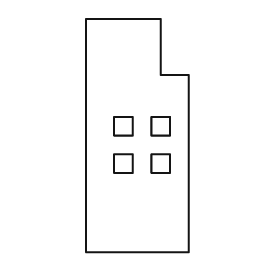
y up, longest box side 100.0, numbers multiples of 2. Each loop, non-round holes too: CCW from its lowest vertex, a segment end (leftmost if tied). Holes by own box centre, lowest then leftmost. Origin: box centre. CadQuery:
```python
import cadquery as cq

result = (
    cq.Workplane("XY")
    .moveTo(-22.0, -50.0)
    .lineTo(22.0, -50.0)
    .lineTo(22.0, 26.0)
    .lineTo(10.0, 26.0)
    .lineTo(10.0, 50.0)
    .lineTo(-22.0, 50.0)
    .close()
    .moveTo(-10.0, -16.0)
    .lineTo(-2.0, -16.0)
    .lineTo(-2.0, -8.0)
    .lineTo(-10.0, -8.0)
    .close()
    .moveTo(6.0, -16.0)
    .lineTo(14.0, -16.0)
    .lineTo(14.0, -8.0)
    .lineTo(6.0, -8.0)
    .close()
    .moveTo(-10.0, 0.0)
    .lineTo(-2.0, 0.0)
    .lineTo(-2.0, 8.0)
    .lineTo(-10.0, 8.0)
    .close()
    .moveTo(6.0, 0.0)
    .lineTo(14.0, 0.0)
    .lineTo(14.0, 8.0)
    .lineTo(6.0, 8.0)
    .close()
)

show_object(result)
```